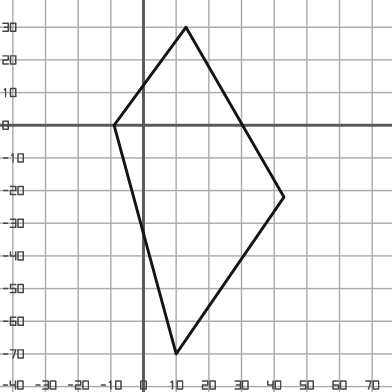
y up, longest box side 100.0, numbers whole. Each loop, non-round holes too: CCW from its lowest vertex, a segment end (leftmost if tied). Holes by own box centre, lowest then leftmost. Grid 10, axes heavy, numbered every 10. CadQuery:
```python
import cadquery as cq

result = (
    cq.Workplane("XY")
    .moveTo(10.0, -70.0)
    .lineTo(43.0, -22.0)
    .lineTo(13.0, 30.0)
    .lineTo(-9.0, 0.0)
    .close()
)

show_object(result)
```